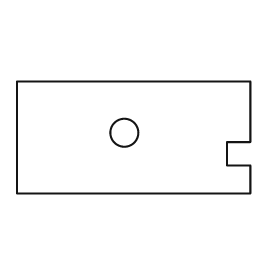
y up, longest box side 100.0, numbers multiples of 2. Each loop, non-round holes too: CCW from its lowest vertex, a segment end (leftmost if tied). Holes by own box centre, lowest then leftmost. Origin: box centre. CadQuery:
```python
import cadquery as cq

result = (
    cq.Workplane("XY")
    .moveTo(-50.0, -24.0)
    .lineTo(50.0, -24.0)
    .lineTo(50.0, -12.0)
    .lineTo(40.0, -12.0)
    .lineTo(40.0, -2.0)
    .lineTo(50.0, -2.0)
    .lineTo(50.0, 24.0)
    .lineTo(-50.0, 24.0)
    .close()
    .moveTo(-4.0, 2.0)
    .circle(6.0)
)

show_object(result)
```